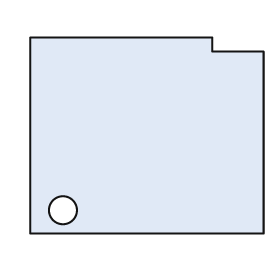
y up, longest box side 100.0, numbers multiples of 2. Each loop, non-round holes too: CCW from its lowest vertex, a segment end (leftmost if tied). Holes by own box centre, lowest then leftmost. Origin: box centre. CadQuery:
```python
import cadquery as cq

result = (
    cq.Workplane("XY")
    .moveTo(-50.0, -42.0)
    .lineTo(50.0, -42.0)
    .lineTo(50.0, 36.0)
    .lineTo(28.0, 36.0)
    .lineTo(28.0, 42.0)
    .lineTo(-50.0, 42.0)
    .close()
    .moveTo(-36.0, -32.0)
    .circle(6.0)
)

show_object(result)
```